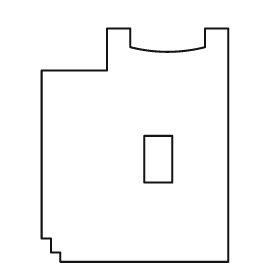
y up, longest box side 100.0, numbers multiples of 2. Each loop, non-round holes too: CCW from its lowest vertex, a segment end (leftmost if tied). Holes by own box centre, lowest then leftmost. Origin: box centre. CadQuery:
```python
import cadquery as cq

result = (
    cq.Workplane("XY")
    .moveTo(-32.0, -50.0)
    .lineTo(40.0, -50.0)
    .lineTo(40.0, 50.0)
    .lineTo(30.0, 50.0)
    .lineTo(30.0, 42.0)
    .threePointArc((14.0, 40.0), (-2.0, 42.0))
    .lineTo(-2.0, 50.0)
    .lineTo(-12.0, 50.0)
    .lineTo(-12.0, 32.0)
    .lineTo(-40.0, 32.0)
    .lineTo(-40.0, -40.0)
    .lineTo(-36.0, -40.0)
    .lineTo(-36.0, -46.0)
    .lineTo(-32.0, -46.0)
    .close()
    .moveTo(4.0, -16.0)
    .lineTo(16.0, -16.0)
    .lineTo(16.0, 4.0)
    .lineTo(4.0, 4.0)
    .close()
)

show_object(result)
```